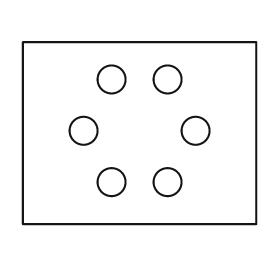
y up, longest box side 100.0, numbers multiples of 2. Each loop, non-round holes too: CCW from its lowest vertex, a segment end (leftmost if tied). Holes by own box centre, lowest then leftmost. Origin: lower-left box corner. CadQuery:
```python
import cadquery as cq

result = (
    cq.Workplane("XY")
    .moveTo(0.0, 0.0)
    .lineTo(100.0, 0.0)
    .lineTo(100.0, 78.0)
    .lineTo(0.0, 78.0)
    .close()
    .moveTo(38.0, 18.0)
    .circle(6.0)
    .moveTo(62.0, 18.0)
    .circle(6.0)
    .moveTo(26.0, 40.0)
    .circle(6.0)
    .moveTo(74.0, 40.0)
    .circle(6.0)
    .moveTo(38.0, 62.0)
    .circle(6.0)
    .moveTo(62.0, 62.0)
    .circle(6.0)
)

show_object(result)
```